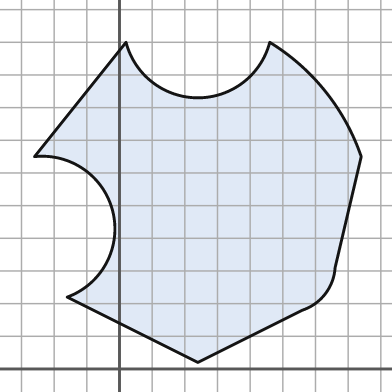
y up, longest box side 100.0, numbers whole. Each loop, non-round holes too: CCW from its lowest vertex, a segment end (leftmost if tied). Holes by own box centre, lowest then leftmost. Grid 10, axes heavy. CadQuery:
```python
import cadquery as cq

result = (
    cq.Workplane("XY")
    .moveTo(24.0, 2.0)
    .lineTo(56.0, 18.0)
    .threePointArc((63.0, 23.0), (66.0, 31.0))
    .lineTo(74.0, 65.0)
    .threePointArc((63.0, 85.0), (46.0, 100.0))
    .threePointArc((24.0, 83.0), (2.0, 100.0))
    .lineTo(-26.0, 65.0)
    .threePointArc((-2.0, 48.0), (-16.0, 22.0))
    .close()
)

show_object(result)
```